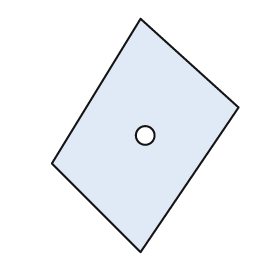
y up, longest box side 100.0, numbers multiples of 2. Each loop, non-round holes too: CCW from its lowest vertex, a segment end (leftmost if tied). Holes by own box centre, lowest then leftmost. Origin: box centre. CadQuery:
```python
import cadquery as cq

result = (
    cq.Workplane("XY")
    .moveTo(-2.0, -50.0)
    .lineTo(40.0, 12.0)
    .lineTo(-2.0, 50.0)
    .lineTo(-40.0, -12.0)
    .close()
    .moveTo(0.0, 0.0)
    .circle(4.0)
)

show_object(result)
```